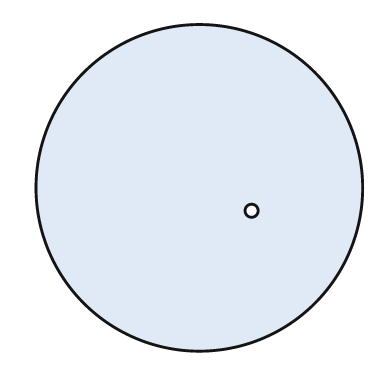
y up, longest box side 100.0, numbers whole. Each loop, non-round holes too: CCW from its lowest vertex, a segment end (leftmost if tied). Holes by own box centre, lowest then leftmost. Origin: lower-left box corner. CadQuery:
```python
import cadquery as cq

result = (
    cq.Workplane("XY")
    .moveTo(50.0, 50.0)
    .circle(50.0)
    .moveTo(66.0, 43.0)
    .circle(2.0)
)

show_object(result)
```